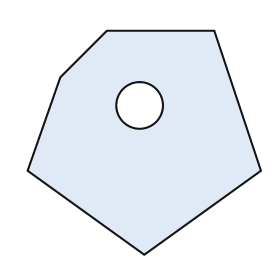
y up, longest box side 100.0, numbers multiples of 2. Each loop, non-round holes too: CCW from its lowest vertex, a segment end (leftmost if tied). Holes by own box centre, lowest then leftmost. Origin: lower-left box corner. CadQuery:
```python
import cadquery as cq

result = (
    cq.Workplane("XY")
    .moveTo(50.0, 0.0)
    .lineTo(100.0, 36.0)
    .lineTo(80.0, 96.0)
    .lineTo(34.0, 96.0)
    .lineTo(14.0, 76.0)
    .lineTo(0.0, 36.0)
    .close()
    .moveTo(48.0, 64.0)
    .circle(10.0)
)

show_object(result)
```